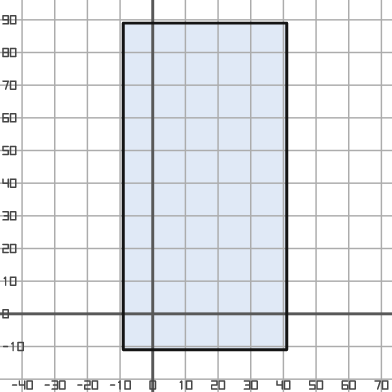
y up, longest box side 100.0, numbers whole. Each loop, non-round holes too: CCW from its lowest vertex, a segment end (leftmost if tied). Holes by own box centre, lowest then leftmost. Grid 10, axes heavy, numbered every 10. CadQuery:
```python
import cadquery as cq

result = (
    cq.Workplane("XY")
    .moveTo(-9.0, -11.0)
    .lineTo(41.0, -11.0)
    .lineTo(41.0, 89.0)
    .lineTo(-9.0, 89.0)
    .close()
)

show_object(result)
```